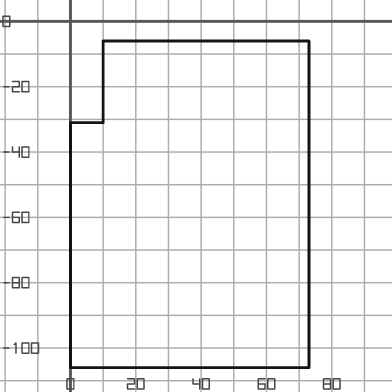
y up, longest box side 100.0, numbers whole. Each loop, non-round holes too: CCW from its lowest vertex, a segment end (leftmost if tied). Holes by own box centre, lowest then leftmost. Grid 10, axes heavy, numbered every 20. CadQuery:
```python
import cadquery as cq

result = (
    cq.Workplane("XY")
    .moveTo(0.0, -106.0)
    .lineTo(73.0, -106.0)
    .lineTo(73.0, -6.0)
    .lineTo(10.0, -6.0)
    .lineTo(10.0, -31.0)
    .lineTo(0.0, -31.0)
    .close()
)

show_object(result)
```